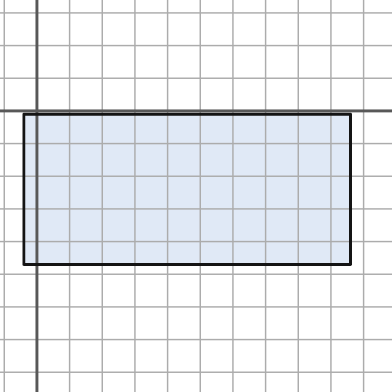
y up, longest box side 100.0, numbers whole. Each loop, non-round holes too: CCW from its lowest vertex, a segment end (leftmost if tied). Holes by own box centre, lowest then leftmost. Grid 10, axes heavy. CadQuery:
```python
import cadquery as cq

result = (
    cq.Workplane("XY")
    .moveTo(-4.0, -47.0)
    .lineTo(96.0, -47.0)
    .lineTo(96.0, -1.0)
    .lineTo(-4.0, -1.0)
    .close()
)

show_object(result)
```